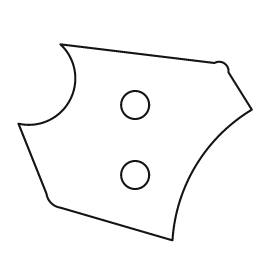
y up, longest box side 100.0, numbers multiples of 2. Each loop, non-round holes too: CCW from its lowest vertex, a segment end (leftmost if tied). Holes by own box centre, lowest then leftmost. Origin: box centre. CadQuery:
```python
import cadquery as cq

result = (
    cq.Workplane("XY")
    .moveTo(16.0, -42.0)
    .threePointArc((26.0, -10.0), (50.0, 14.0))
    .lineTo(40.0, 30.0)
    .threePointArc((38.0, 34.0), (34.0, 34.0))
    .lineTo(-32.0, 42.0)
    .threePointArc((-28.0, 18.0), (-50.0, 8.0))
    .lineTo(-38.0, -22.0)
    .threePointArc((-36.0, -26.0), (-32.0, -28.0))
    .close()
    .moveTo(0.0, -14.0)
    .circle(6.0)
    .moveTo(0.0, 16.0)
    .circle(6.0)
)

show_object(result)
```